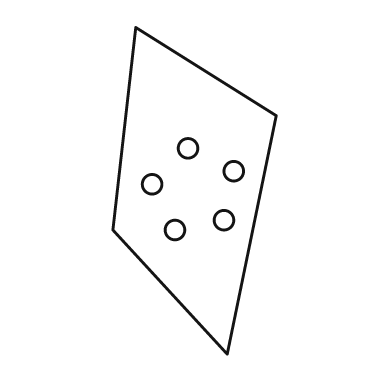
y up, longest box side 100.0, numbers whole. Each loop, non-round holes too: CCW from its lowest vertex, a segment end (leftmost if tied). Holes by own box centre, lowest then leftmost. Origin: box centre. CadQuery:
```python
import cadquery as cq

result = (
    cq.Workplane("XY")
    .moveTo(10.0, -50.0)
    .lineTo(25.0, 23.0)
    .lineTo(-18.0, 50.0)
    .lineTo(-25.0, -12.0)
    .close()
    .moveTo(-6.0, -12.0)
    .circle(3.0)
    .moveTo(9.0, -9.0)
    .circle(3.0)
    .moveTo(-13.0, 2.0)
    .circle(3.0)
    .moveTo(12.0, 6.0)
    .circle(3.0)
    .moveTo(-2.0, 13.0)
    .circle(3.0)
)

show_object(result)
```